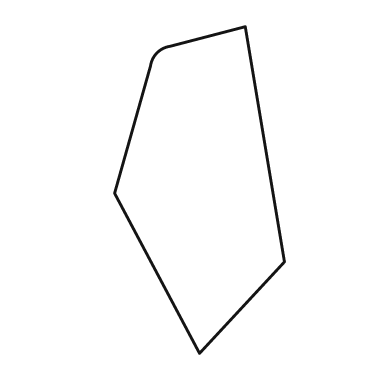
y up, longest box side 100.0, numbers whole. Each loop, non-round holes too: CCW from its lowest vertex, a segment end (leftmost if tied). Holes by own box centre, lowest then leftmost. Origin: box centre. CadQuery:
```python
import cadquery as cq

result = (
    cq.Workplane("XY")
    .moveTo(0.0, -50.0)
    .lineTo(26.0, -22.0)
    .lineTo(14.0, 50.0)
    .lineTo(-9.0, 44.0)
    .threePointArc((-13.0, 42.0), (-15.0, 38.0))
    .lineTo(-26.0, -1.0)
    .close()
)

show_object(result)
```